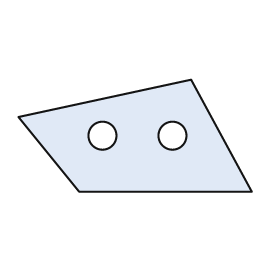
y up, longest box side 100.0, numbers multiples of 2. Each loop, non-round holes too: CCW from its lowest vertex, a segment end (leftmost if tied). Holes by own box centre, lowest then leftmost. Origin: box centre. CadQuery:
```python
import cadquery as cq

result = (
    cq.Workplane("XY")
    .moveTo(-24.0, -24.0)
    .lineTo(50.0, -24.0)
    .lineTo(24.0, 24.0)
    .lineTo(-50.0, 8.0)
    .close()
    .moveTo(-14.0, 0.0)
    .circle(6.0)
    .moveTo(16.0, 0.0)
    .circle(6.0)
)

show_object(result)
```